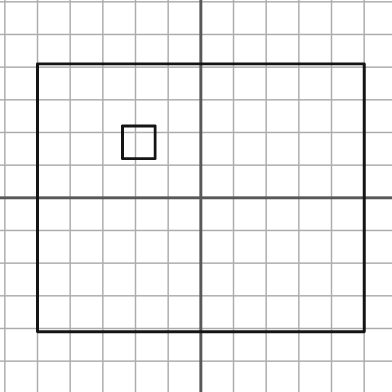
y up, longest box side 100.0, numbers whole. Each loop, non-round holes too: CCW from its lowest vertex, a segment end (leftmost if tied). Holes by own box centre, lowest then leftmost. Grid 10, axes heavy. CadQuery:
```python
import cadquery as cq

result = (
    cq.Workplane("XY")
    .moveTo(-50.0, -41.0)
    .lineTo(50.0, -41.0)
    .lineTo(50.0, 41.0)
    .lineTo(-50.0, 41.0)
    .close()
    .moveTo(-24.0, 12.0)
    .lineTo(-14.0, 12.0)
    .lineTo(-14.0, 22.0)
    .lineTo(-24.0, 22.0)
    .close()
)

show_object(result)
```